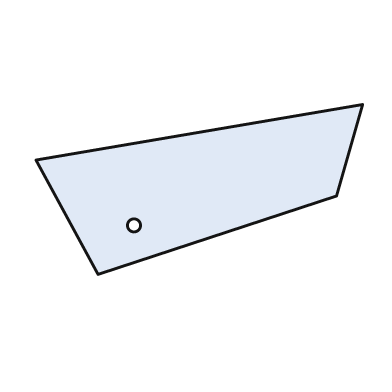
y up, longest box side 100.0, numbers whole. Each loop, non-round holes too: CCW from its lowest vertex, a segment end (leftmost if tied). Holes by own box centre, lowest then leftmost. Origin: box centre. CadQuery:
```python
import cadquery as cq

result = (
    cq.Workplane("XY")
    .moveTo(-31.0, -26.0)
    .lineTo(42.0, -2.0)
    .lineTo(50.0, 26.0)
    .lineTo(-50.0, 9.0)
    .close()
    .moveTo(-20.0, -11.0)
    .circle(2.0)
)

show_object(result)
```